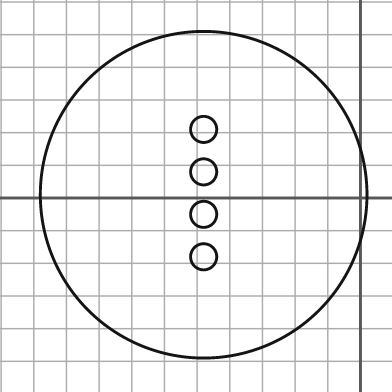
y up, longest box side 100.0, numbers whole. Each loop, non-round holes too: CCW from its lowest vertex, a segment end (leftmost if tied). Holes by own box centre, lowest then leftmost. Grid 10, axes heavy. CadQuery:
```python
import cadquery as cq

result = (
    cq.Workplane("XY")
    .moveTo(-48.0, 1.0)
    .circle(50.0)
    .moveTo(-48.0, -18.0)
    .circle(4.0)
    .moveTo(-48.0, -5.0)
    .circle(4.0)
    .moveTo(-48.0, 8.0)
    .circle(4.0)
    .moveTo(-48.0, 21.0)
    .circle(4.0)
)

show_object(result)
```